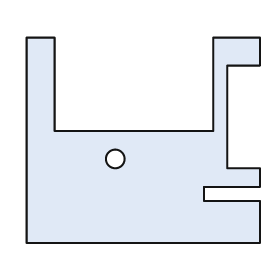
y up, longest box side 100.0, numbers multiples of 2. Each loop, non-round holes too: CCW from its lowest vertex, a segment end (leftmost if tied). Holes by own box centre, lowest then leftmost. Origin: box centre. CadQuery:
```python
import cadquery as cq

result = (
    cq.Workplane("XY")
    .moveTo(-50.0, -44.0)
    .lineTo(50.0, -44.0)
    .lineTo(50.0, -26.0)
    .lineTo(26.0, -26.0)
    .lineTo(26.0, -20.0)
    .lineTo(50.0, -20.0)
    .lineTo(50.0, -12.0)
    .lineTo(36.0, -12.0)
    .lineTo(36.0, 32.0)
    .lineTo(50.0, 32.0)
    .lineTo(50.0, 44.0)
    .lineTo(30.0, 44.0)
    .lineTo(30.0, 4.0)
    .lineTo(-38.0, 4.0)
    .lineTo(-38.0, 44.0)
    .lineTo(-50.0, 44.0)
    .close()
    .moveTo(-12.0, -8.0)
    .circle(4.0)
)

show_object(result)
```